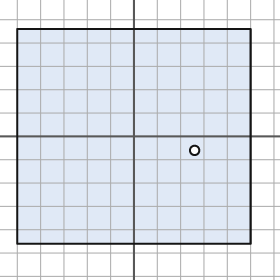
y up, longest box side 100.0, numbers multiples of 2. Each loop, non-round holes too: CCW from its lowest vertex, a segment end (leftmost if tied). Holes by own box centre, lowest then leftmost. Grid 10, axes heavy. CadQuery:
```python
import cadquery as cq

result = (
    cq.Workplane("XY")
    .moveTo(-50.0, -46.0)
    .lineTo(50.0, -46.0)
    .lineTo(50.0, 46.0)
    .lineTo(-50.0, 46.0)
    .close()
    .moveTo(26.0, -6.0)
    .circle(2.0)
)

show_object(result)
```